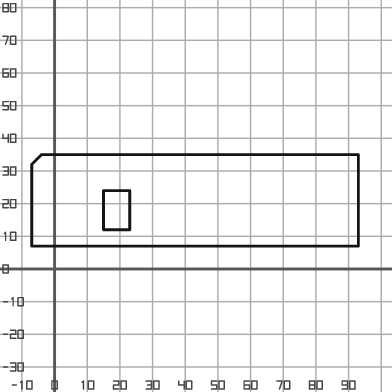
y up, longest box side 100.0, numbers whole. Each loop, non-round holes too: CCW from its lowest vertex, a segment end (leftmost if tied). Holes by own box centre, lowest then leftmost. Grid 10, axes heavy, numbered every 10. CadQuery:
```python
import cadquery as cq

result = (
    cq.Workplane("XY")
    .moveTo(-7.0, 7.0)
    .lineTo(93.0, 7.0)
    .lineTo(93.0, 35.0)
    .lineTo(-4.0, 35.0)
    .lineTo(-7.0, 32.0)
    .close()
    .moveTo(15.0, 12.0)
    .lineTo(23.0, 12.0)
    .lineTo(23.0, 24.0)
    .lineTo(15.0, 24.0)
    .close()
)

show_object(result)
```